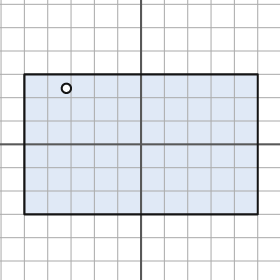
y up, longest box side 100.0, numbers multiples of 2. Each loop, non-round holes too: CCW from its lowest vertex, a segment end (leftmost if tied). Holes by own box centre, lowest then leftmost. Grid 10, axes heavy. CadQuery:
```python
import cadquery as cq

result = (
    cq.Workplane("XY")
    .moveTo(-50.0, -30.0)
    .lineTo(50.0, -30.0)
    .lineTo(50.0, 30.0)
    .lineTo(-50.0, 30.0)
    .close()
    .moveTo(-32.0, 24.0)
    .circle(2.0)
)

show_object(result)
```